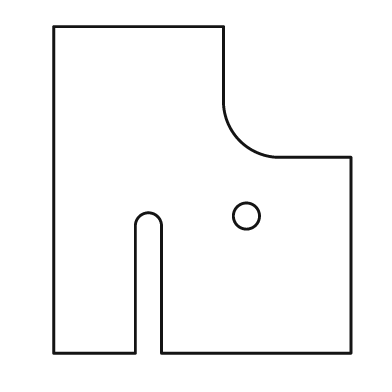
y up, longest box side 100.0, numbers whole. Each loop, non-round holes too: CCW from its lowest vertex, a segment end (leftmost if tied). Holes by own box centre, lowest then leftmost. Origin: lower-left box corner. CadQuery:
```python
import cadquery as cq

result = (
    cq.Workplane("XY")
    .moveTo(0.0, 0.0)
    .lineTo(25.0, 0.0)
    .lineTo(25.0, 39.0)
    .threePointArc((29.0, 43.0), (33.0, 39.0))
    .lineTo(33.0, 0.0)
    .lineTo(91.0, 0.0)
    .lineTo(91.0, 60.0)
    .lineTo(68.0, 60.0)
    .threePointArc((57.0, 65.0), (52.0, 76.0))
    .lineTo(52.0, 100.0)
    .lineTo(0.0, 100.0)
    .close()
    .moveTo(59.0, 42.0)
    .circle(4.0)
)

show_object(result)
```